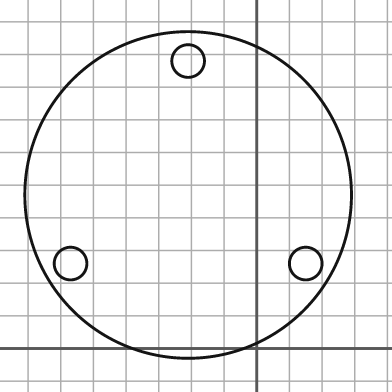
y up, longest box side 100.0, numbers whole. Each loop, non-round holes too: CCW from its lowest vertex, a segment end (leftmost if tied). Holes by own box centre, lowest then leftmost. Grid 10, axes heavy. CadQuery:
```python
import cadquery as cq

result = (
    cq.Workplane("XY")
    .moveTo(-21.0, 47.0)
    .circle(50.0)
    .moveTo(-57.0, 26.0)
    .circle(5.0)
    .moveTo(15.0, 26.0)
    .circle(5.0)
    .moveTo(-21.0, 88.0)
    .circle(5.0)
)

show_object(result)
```